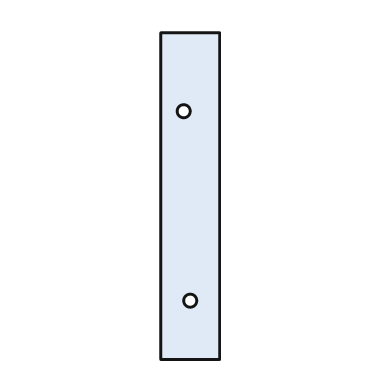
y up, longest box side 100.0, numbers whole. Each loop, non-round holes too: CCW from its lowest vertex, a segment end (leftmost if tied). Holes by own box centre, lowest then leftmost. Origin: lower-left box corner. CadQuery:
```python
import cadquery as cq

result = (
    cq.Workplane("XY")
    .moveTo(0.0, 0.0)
    .lineTo(18.0, 0.0)
    .lineTo(18.0, 100.0)
    .lineTo(0.0, 100.0)
    .close()
    .moveTo(9.0, 18.0)
    .circle(2.0)
    .moveTo(7.0, 76.0)
    .circle(2.0)
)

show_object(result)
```